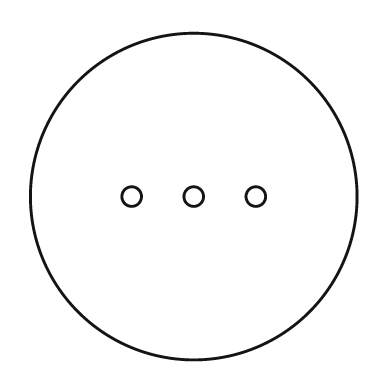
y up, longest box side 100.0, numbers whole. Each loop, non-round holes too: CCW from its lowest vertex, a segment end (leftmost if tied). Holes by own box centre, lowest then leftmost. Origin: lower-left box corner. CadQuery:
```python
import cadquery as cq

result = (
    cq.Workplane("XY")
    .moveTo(50.0, 50.0)
    .circle(50.0)
    .moveTo(31.0, 50.0)
    .circle(3.0)
    .moveTo(50.0, 50.0)
    .circle(3.0)
    .moveTo(69.0, 50.0)
    .circle(3.0)
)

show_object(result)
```